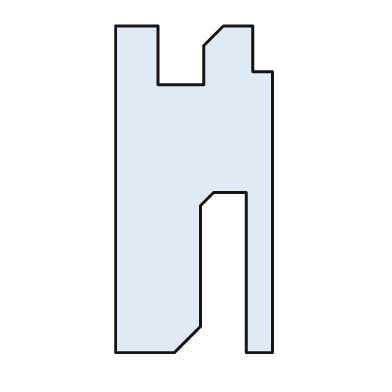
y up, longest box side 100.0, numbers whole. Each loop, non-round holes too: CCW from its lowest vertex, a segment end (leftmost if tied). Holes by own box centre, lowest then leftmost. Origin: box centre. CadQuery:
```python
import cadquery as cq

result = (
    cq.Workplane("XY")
    .moveTo(-24.0, -50.0)
    .lineTo(-6.0, -50.0)
    .lineTo(2.0, -42.0)
    .lineTo(2.0, -5.0)
    .lineTo(6.0, -1.0)
    .lineTo(16.0, -1.0)
    .lineTo(16.0, -50.0)
    .lineTo(24.0, -50.0)
    .lineTo(24.0, 36.0)
    .lineTo(18.0, 36.0)
    .lineTo(18.0, 50.0)
    .lineTo(9.0, 50.0)
    .lineTo(3.0, 44.0)
    .lineTo(3.0, 32.0)
    .lineTo(-11.0, 32.0)
    .lineTo(-11.0, 50.0)
    .lineTo(-24.0, 50.0)
    .close()
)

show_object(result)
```